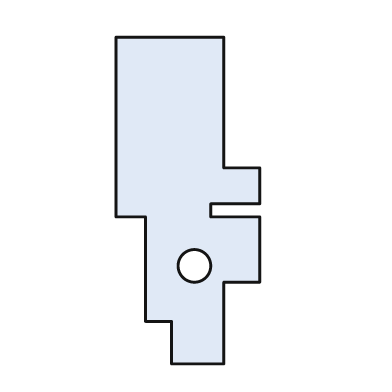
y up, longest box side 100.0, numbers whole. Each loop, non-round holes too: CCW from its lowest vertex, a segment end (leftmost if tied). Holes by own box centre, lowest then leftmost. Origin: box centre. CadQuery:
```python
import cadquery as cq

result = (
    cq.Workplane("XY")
    .moveTo(-5.0, -50.0)
    .lineTo(11.0, -50.0)
    .lineTo(11.0, -25.0)
    .lineTo(22.0, -25.0)
    .lineTo(22.0, -5.0)
    .lineTo(7.0, -5.0)
    .lineTo(7.0, -1.0)
    .lineTo(22.0, -1.0)
    .lineTo(22.0, 10.0)
    .lineTo(11.0, 10.0)
    .lineTo(11.0, 50.0)
    .lineTo(-22.0, 50.0)
    .lineTo(-22.0, -5.0)
    .lineTo(-13.0, -5.0)
    .lineTo(-13.0, -37.0)
    .lineTo(-5.0, -37.0)
    .close()
    .moveTo(2.0, -20.0)
    .circle(5.0)
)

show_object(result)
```